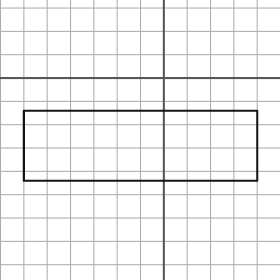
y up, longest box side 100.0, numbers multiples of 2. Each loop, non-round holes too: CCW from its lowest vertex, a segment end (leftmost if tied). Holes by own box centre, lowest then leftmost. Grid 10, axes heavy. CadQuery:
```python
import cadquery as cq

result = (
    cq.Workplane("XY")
    .moveTo(-60.0, -44.0)
    .lineTo(40.0, -44.0)
    .lineTo(40.0, -14.0)
    .lineTo(-60.0, -14.0)
    .close()
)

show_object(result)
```